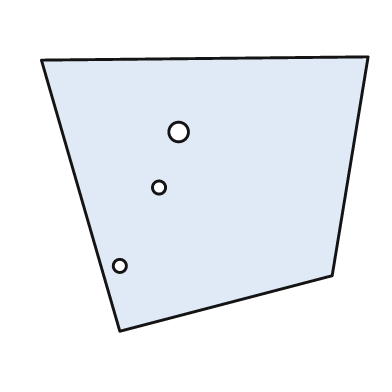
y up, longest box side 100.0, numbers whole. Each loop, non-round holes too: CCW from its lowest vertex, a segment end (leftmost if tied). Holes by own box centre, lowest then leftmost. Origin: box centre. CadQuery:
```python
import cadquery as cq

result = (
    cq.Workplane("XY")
    .moveTo(-26.0, -42.0)
    .lineTo(39.0, -25.0)
    .lineTo(50.0, 42.0)
    .lineTo(-50.0, 41.0)
    .close()
    .moveTo(-26.0, -22.0)
    .circle(2.0)
    .moveTo(-14.0, 2.0)
    .circle(2.0)
    .moveTo(-8.0, 19.0)
    .circle(3.0)
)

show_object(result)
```